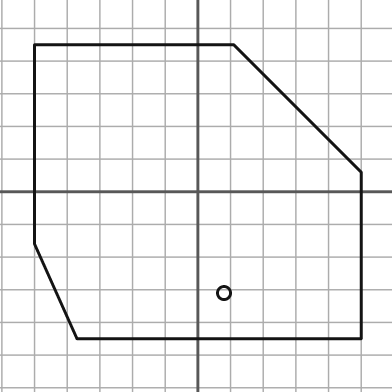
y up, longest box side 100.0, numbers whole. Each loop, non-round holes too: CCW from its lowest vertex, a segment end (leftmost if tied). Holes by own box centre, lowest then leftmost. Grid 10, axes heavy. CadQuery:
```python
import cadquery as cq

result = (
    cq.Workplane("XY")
    .moveTo(-37.0, -45.0)
    .lineTo(50.0, -45.0)
    .lineTo(50.0, 6.0)
    .lineTo(11.0, 45.0)
    .lineTo(-50.0, 45.0)
    .lineTo(-50.0, -16.0)
    .close()
    .moveTo(8.0, -31.0)
    .circle(2.0)
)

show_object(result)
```